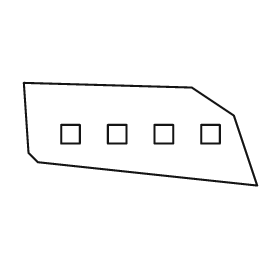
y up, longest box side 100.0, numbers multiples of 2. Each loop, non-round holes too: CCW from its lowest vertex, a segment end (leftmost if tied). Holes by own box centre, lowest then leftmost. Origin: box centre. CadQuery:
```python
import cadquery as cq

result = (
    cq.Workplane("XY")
    .moveTo(50.0, -22.0)
    .lineTo(40.0, 8.0)
    .lineTo(22.0, 20.0)
    .lineTo(-50.0, 22.0)
    .lineTo(-48.0, -8.0)
    .lineTo(-44.0, -12.0)
    .close()
    .moveTo(-34.0, -4.0)
    .lineTo(-26.0, -4.0)
    .lineTo(-26.0, 4.0)
    .lineTo(-34.0, 4.0)
    .close()
    .moveTo(-14.0, -4.0)
    .lineTo(-6.0, -4.0)
    .lineTo(-6.0, 4.0)
    .lineTo(-14.0, 4.0)
    .close()
    .moveTo(6.0, -4.0)
    .lineTo(14.0, -4.0)
    .lineTo(14.0, 4.0)
    .lineTo(6.0, 4.0)
    .close()
    .moveTo(26.0, -4.0)
    .lineTo(34.0, -4.0)
    .lineTo(34.0, 4.0)
    .lineTo(26.0, 4.0)
    .close()
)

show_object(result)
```